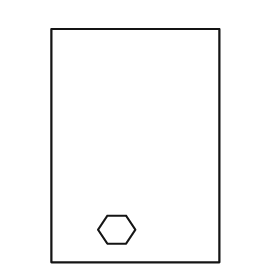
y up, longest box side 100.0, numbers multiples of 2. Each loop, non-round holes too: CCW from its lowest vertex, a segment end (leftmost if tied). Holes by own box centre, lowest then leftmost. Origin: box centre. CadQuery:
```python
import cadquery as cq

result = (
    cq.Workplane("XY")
    .moveTo(-36.0, -50.0)
    .lineTo(36.0, -50.0)
    .lineTo(36.0, 50.0)
    .lineTo(-36.0, 50.0)
    .close()
    .moveTo(-12.0, -42.0)
    .lineTo(-4.0, -42.0)
    .lineTo(0.0, -36.0)
    .lineTo(-4.0, -30.0)
    .lineTo(-12.0, -30.0)
    .lineTo(-16.0, -36.0)
    .close()
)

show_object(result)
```